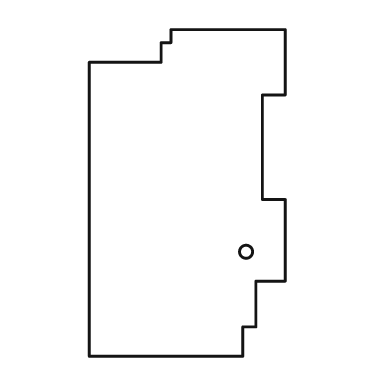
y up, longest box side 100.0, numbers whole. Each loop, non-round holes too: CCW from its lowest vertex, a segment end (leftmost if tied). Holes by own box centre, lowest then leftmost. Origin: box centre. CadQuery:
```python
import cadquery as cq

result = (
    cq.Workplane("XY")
    .moveTo(-30.0, -50.0)
    .lineTo(17.0, -50.0)
    .lineTo(17.0, -41.0)
    .lineTo(21.0, -41.0)
    .lineTo(21.0, -27.0)
    .lineTo(30.0, -27.0)
    .lineTo(30.0, -2.0)
    .lineTo(23.0, -2.0)
    .lineTo(23.0, 30.0)
    .lineTo(30.0, 30.0)
    .lineTo(30.0, 50.0)
    .lineTo(-5.0, 50.0)
    .lineTo(-5.0, 46.0)
    .lineTo(-8.0, 46.0)
    .lineTo(-8.0, 40.0)
    .lineTo(-30.0, 40.0)
    .close()
    .moveTo(18.0, -18.0)
    .circle(2.0)
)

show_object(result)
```